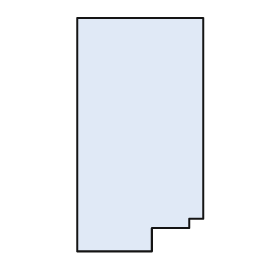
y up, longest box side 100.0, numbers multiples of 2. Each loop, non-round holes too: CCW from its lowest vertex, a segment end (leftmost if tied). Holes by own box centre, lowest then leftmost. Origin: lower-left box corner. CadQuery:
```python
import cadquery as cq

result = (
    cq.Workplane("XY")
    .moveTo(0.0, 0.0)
    .lineTo(32.0, 0.0)
    .lineTo(32.0, 10.0)
    .lineTo(48.0, 10.0)
    .lineTo(48.0, 14.0)
    .lineTo(54.0, 14.0)
    .lineTo(54.0, 100.0)
    .lineTo(0.0, 100.0)
    .close()
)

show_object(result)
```